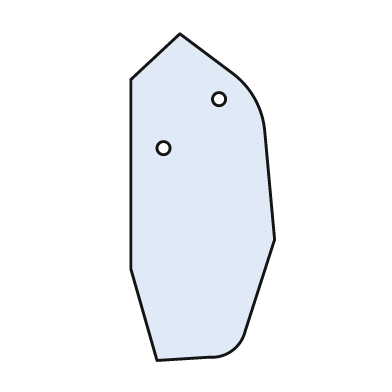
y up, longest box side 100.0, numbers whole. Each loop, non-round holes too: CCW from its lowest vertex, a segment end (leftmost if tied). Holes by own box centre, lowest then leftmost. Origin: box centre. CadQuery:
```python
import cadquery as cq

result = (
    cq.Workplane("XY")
    .moveTo(-14.0, -50.0)
    .lineTo(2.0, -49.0)
    .threePointArc((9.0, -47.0), (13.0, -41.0))
    .lineTo(22.0, -13.0)
    .lineTo(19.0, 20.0)
    .threePointArc((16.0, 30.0), (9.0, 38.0))
    .lineTo(-7.0, 50.0)
    .lineTo(-22.0, 36.0)
    .lineTo(-22.0, -22.0)
    .close()
    .moveTo(-12.0, 15.0)
    .circle(2.0)
    .moveTo(5.0, 30.0)
    .circle(2.0)
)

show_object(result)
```